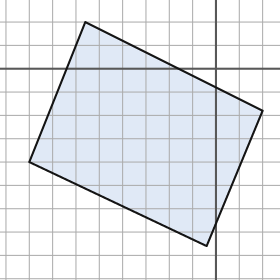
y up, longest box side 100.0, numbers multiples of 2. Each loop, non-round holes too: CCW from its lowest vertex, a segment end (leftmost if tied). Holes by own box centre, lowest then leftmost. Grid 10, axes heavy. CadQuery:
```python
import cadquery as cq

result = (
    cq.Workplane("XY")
    .moveTo(-4.0, -76.0)
    .lineTo(20.0, -18.0)
    .lineTo(-56.0, 20.0)
    .lineTo(-80.0, -40.0)
    .close()
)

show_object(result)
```